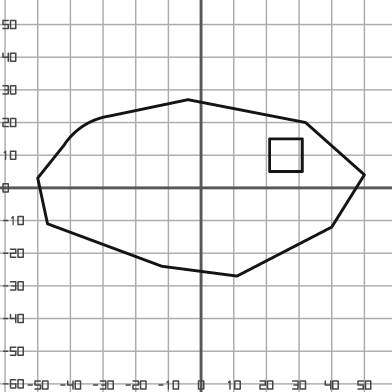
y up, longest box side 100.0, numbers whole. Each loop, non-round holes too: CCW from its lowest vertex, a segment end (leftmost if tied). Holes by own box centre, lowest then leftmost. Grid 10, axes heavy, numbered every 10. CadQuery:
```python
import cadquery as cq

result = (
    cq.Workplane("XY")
    .moveTo(11.0, -27.0)
    .lineTo(40.0, -12.0)
    .lineTo(50.0, 4.0)
    .lineTo(32.0, 20.0)
    .lineTo(-4.0, 27.0)
    .lineTo(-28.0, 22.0)
    .threePointArc((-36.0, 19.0), (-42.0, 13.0))
    .lineTo(-50.0, 3.0)
    .lineTo(-47.0, -11.0)
    .lineTo(-12.0, -24.0)
    .close()
    .moveTo(21.0, 5.0)
    .lineTo(31.0, 5.0)
    .lineTo(31.0, 15.0)
    .lineTo(21.0, 15.0)
    .close()
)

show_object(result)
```